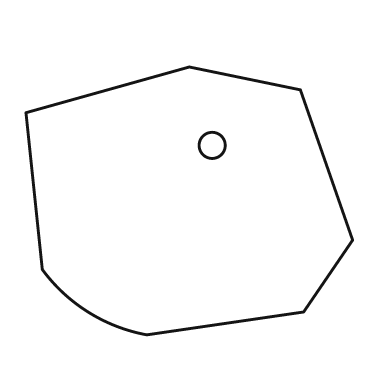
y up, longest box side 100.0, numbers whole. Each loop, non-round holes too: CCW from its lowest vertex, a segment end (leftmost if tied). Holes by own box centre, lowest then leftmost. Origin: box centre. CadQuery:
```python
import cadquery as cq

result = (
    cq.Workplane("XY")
    .moveTo(-13.0, -41.0)
    .lineTo(35.0, -34.0)
    .lineTo(50.0, -12.0)
    .lineTo(34.0, 34.0)
    .lineTo(0.0, 41.0)
    .lineTo(-50.0, 27.0)
    .lineTo(-45.0, -21.0)
    .threePointArc((-31.0, -34.0), (-13.0, -41.0))
    .close()
    .moveTo(7.0, 17.0)
    .circle(4.0)
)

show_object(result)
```